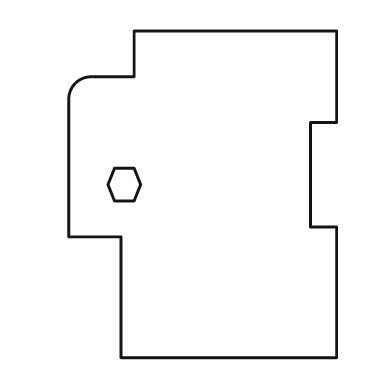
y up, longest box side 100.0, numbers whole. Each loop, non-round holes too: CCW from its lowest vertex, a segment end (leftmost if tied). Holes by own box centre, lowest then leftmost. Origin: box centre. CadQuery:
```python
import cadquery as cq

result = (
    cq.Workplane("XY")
    .moveTo(-25.0, -50.0)
    .lineTo(41.0, -50.0)
    .lineTo(41.0, -10.0)
    .lineTo(33.0, -10.0)
    .lineTo(33.0, 22.0)
    .lineTo(41.0, 22.0)
    .lineTo(41.0, 50.0)
    .lineTo(-21.0, 50.0)
    .lineTo(-21.0, 36.0)
    .lineTo(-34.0, 36.0)
    .threePointArc((-39.0, 34.0), (-41.0, 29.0))
    .lineTo(-41.0, -13.0)
    .lineTo(-25.0, -13.0)
    .close()
    .moveTo(-27.0, -2.0)
    .lineTo(-21.0, -2.0)
    .lineTo(-19.0, 3.0)
    .lineTo(-21.0, 8.0)
    .lineTo(-27.0, 8.0)
    .lineTo(-29.0, 3.0)
    .close()
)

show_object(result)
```